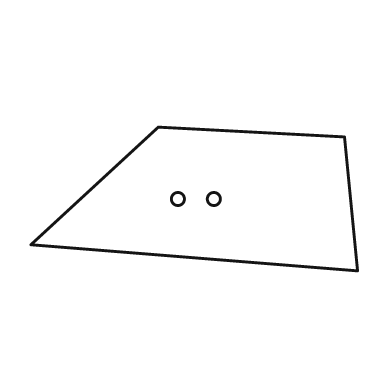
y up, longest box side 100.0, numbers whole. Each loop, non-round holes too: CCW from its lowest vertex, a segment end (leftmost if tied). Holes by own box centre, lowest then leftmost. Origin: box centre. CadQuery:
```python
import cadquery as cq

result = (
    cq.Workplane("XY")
    .moveTo(50.0, -22.0)
    .lineTo(46.0, 19.0)
    .lineTo(-11.0, 22.0)
    .lineTo(-50.0, -14.0)
    .close()
    .moveTo(-5.0, 0.0)
    .circle(2.0)
    .moveTo(6.0, 0.0)
    .circle(2.0)
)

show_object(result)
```